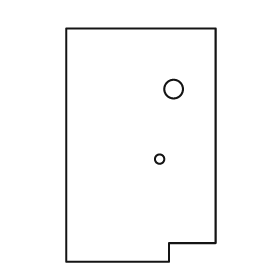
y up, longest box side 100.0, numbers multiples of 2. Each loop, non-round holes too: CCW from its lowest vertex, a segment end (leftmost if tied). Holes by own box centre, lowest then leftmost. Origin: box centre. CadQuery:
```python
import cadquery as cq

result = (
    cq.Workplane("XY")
    .moveTo(-32.0, -50.0)
    .lineTo(12.0, -50.0)
    .lineTo(12.0, -42.0)
    .lineTo(32.0, -42.0)
    .lineTo(32.0, 50.0)
    .lineTo(-32.0, 50.0)
    .close()
    .moveTo(8.0, -6.0)
    .circle(2.0)
    .moveTo(14.0, 24.0)
    .circle(4.0)
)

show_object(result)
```